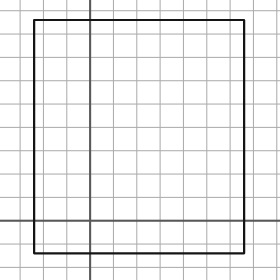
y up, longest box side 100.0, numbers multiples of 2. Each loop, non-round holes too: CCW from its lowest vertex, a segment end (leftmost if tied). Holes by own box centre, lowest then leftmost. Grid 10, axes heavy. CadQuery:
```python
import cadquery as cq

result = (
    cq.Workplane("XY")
    .moveTo(-24.0, -14.0)
    .lineTo(66.0, -14.0)
    .lineTo(66.0, 86.0)
    .lineTo(-24.0, 86.0)
    .close()
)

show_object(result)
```